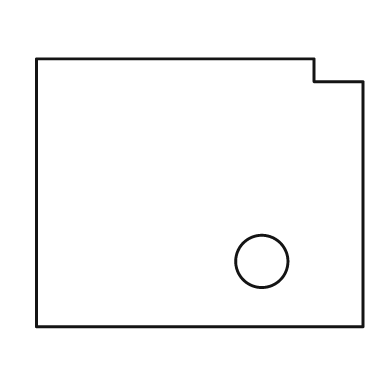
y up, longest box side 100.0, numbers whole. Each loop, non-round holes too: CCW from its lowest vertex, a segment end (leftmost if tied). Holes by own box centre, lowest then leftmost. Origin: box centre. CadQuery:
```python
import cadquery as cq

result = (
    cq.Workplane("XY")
    .moveTo(-50.0, -41.0)
    .lineTo(50.0, -41.0)
    .lineTo(50.0, 34.0)
    .lineTo(35.0, 34.0)
    .lineTo(35.0, 41.0)
    .lineTo(-50.0, 41.0)
    .close()
    .moveTo(19.0, -21.0)
    .circle(8.0)
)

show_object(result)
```